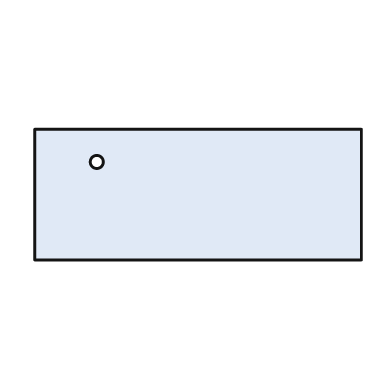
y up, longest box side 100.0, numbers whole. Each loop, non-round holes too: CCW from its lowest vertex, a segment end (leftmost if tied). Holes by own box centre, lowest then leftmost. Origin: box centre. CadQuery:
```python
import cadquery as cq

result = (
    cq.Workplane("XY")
    .moveTo(-50.0, -20.0)
    .lineTo(50.0, -20.0)
    .lineTo(50.0, 20.0)
    .lineTo(-50.0, 20.0)
    .close()
    .moveTo(-31.0, 10.0)
    .circle(2.0)
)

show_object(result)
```